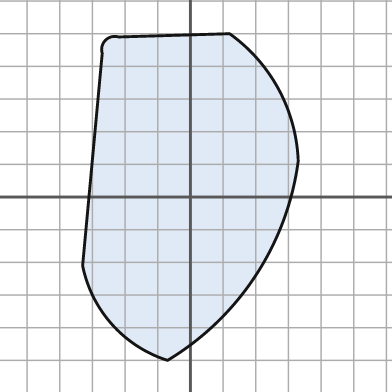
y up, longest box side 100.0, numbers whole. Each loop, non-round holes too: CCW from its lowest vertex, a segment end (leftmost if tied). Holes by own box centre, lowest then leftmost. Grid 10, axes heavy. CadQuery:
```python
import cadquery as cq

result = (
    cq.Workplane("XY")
    .moveTo(-7.0, -50.0)
    .threePointArc((20.0, -24.0), (33.0, 11.0))
    .threePointArc((27.0, 33.0), (12.0, 50.0))
    .lineTo(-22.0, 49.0)
    .threePointArc((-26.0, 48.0), (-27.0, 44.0))
    .lineTo(-33.0, -21.0)
    .threePointArc((-24.0, -39.0), (-7.0, -50.0))
    .close()
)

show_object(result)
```